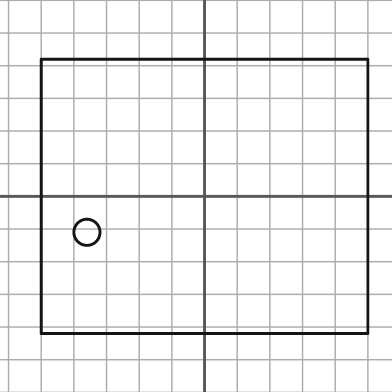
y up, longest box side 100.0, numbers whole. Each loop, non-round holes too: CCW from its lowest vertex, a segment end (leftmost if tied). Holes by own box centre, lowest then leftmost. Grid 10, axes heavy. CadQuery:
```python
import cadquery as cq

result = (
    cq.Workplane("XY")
    .moveTo(-50.0, -42.0)
    .lineTo(50.0, -42.0)
    .lineTo(50.0, 42.0)
    .lineTo(-50.0, 42.0)
    .close()
    .moveTo(-36.0, -11.0)
    .circle(4.0)
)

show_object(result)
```